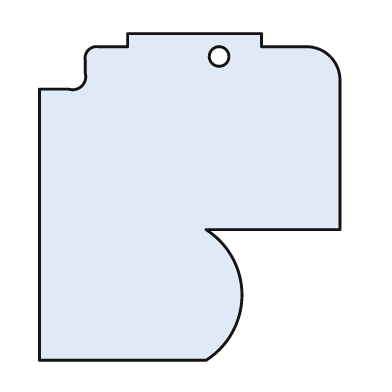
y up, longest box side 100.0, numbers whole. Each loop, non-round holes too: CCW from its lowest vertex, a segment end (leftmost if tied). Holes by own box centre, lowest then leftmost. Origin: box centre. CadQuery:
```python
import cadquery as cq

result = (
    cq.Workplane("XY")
    .moveTo(-46.0, -50.0)
    .lineTo(5.0, -50.0)
    .threePointArc((16.0, -30.0), (5.0, -10.0))
    .lineTo(46.0, -10.0)
    .lineTo(46.0, 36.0)
    .threePointArc((43.0, 43.0), (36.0, 46.0))
    .lineTo(22.0, 46.0)
    .lineTo(22.0, 50.0)
    .lineTo(-19.0, 50.0)
    .lineTo(-19.0, 46.0)
    .lineTo(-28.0, 46.0)
    .threePointArc((-31.0, 45.0), (-32.0, 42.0))
    .lineTo(-32.0, 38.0)
    .threePointArc((-33.0, 34.0), (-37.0, 33.0))
    .lineTo(-46.0, 33.0)
    .close()
    .moveTo(9.0, 43.0)
    .circle(3.0)
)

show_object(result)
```